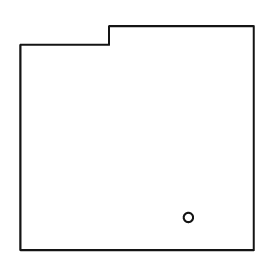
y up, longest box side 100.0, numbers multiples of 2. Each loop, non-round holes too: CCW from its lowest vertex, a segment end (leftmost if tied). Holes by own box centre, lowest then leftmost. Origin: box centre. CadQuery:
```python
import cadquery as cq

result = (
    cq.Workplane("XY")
    .moveTo(-50.0, -48.0)
    .lineTo(50.0, -48.0)
    .lineTo(50.0, 48.0)
    .lineTo(-12.0, 48.0)
    .lineTo(-12.0, 40.0)
    .lineTo(-50.0, 40.0)
    .close()
    .moveTo(22.0, -34.0)
    .circle(2.0)
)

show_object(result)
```